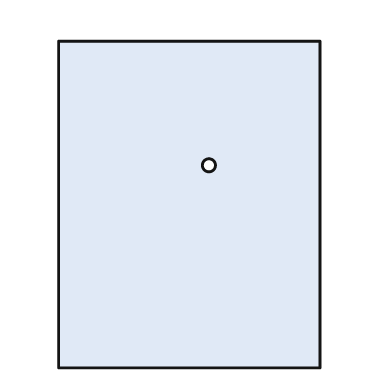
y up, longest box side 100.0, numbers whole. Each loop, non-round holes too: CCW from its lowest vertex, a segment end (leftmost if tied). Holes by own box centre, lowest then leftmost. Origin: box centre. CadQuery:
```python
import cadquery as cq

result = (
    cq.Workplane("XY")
    .moveTo(-40.0, -50.0)
    .lineTo(40.0, -50.0)
    .lineTo(40.0, 50.0)
    .lineTo(-40.0, 50.0)
    .close()
    .moveTo(6.0, 12.0)
    .circle(2.0)
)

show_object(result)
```